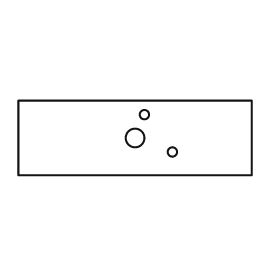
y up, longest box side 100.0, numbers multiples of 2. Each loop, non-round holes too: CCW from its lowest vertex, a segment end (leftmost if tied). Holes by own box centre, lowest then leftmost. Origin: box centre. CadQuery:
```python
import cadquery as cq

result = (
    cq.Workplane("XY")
    .moveTo(-50.0, -16.0)
    .lineTo(50.0, -16.0)
    .lineTo(50.0, 16.0)
    .lineTo(-50.0, 16.0)
    .close()
    .moveTo(16.0, -6.0)
    .circle(2.0)
    .moveTo(0.0, 0.0)
    .circle(4.0)
    .moveTo(4.0, 10.0)
    .circle(2.0)
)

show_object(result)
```